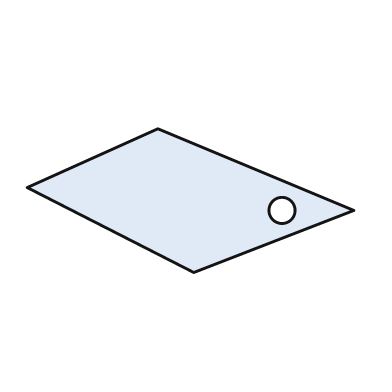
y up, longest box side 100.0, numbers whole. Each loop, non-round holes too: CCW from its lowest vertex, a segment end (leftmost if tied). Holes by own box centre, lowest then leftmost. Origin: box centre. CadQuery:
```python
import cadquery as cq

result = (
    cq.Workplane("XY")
    .moveTo(1.0, -22.0)
    .lineTo(50.0, -3.0)
    .lineTo(-10.0, 22.0)
    .lineTo(-50.0, 4.0)
    .close()
    .moveTo(28.0, -3.0)
    .circle(4.0)
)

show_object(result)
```